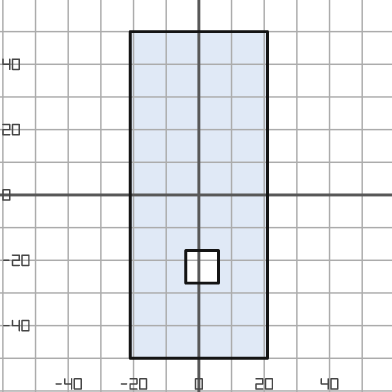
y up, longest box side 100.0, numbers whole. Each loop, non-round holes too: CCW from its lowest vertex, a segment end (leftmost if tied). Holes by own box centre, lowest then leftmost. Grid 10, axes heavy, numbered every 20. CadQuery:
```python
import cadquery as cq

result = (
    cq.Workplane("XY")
    .moveTo(-21.0, -50.0)
    .lineTo(21.0, -50.0)
    .lineTo(21.0, 50.0)
    .lineTo(-21.0, 50.0)
    .close()
    .moveTo(-4.0, -27.0)
    .lineTo(6.0, -27.0)
    .lineTo(6.0, -17.0)
    .lineTo(-4.0, -17.0)
    .close()
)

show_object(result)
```